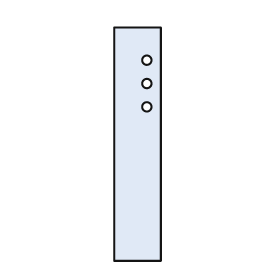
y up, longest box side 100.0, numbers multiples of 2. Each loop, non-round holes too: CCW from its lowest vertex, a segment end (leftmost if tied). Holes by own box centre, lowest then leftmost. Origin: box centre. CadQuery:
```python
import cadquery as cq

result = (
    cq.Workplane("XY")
    .moveTo(-10.0, -50.0)
    .lineTo(10.0, -50.0)
    .lineTo(10.0, 50.0)
    .lineTo(-10.0, 50.0)
    .close()
    .moveTo(4.0, 16.0)
    .circle(2.0)
    .moveTo(4.0, 26.0)
    .circle(2.0)
    .moveTo(4.0, 36.0)
    .circle(2.0)
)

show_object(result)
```